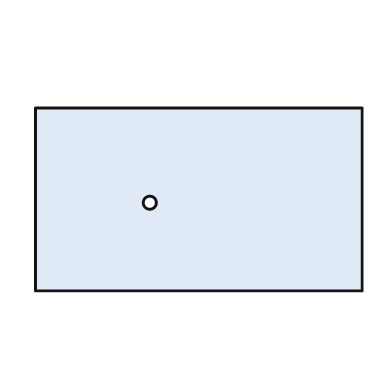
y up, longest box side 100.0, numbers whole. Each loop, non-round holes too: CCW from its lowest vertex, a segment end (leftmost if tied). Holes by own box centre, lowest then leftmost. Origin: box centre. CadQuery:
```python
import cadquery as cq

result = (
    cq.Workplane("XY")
    .moveTo(-50.0, -28.0)
    .lineTo(50.0, -28.0)
    .lineTo(50.0, 28.0)
    .lineTo(-50.0, 28.0)
    .close()
    .moveTo(-15.0, -1.0)
    .circle(2.0)
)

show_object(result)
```